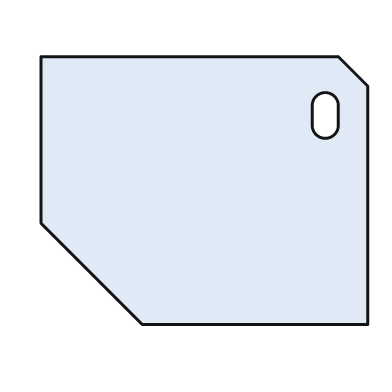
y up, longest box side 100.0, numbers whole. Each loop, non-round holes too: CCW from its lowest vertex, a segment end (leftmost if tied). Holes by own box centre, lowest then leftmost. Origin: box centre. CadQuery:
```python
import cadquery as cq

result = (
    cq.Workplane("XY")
    .moveTo(-19.0, -41.0)
    .lineTo(50.0, -41.0)
    .lineTo(50.0, 32.0)
    .lineTo(41.0, 41.0)
    .lineTo(-50.0, 41.0)
    .lineTo(-50.0, -10.0)
    .close()
    .moveTo(33.0, 20.0)
    .threePointArc((37.0, 16.0), (41.0, 20.0))
    .lineTo(41.0, 26.0)
    .threePointArc((37.0, 30.0), (33.0, 26.0))
    .close()
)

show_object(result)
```